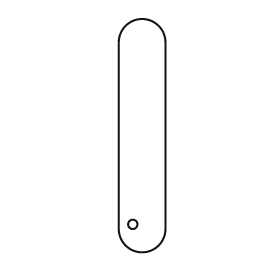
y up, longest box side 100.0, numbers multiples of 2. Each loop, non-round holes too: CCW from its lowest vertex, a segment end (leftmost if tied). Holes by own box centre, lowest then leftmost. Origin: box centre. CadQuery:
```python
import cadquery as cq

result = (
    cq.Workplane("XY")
    .moveTo(-10.0, -40.0)
    .threePointArc((0.0, -50.0), (10.0, -40.0))
    .lineTo(10.0, 40.0)
    .threePointArc((0.0, 50.0), (-10.0, 40.0))
    .close()
    .moveTo(-4.0, -38.0)
    .circle(2.0)
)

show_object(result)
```